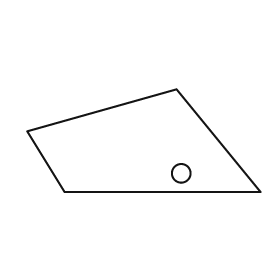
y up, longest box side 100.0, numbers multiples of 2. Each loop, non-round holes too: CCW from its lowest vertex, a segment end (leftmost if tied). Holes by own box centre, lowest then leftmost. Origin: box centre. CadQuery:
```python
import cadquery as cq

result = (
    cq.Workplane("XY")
    .moveTo(-34.0, -22.0)
    .lineTo(50.0, -22.0)
    .lineTo(14.0, 22.0)
    .lineTo(-50.0, 4.0)
    .close()
    .moveTo(16.0, -14.0)
    .circle(4.0)
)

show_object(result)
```